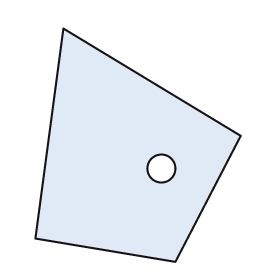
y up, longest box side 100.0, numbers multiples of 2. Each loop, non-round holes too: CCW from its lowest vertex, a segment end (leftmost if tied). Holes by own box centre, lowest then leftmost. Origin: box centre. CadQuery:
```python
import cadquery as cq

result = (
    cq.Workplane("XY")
    .moveTo(16.0, -50.0)
    .lineTo(44.0, 4.0)
    .lineTo(-32.0, 50.0)
    .lineTo(-44.0, -40.0)
    .close()
    .moveTo(10.0, -10.0)
    .circle(6.0)
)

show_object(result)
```